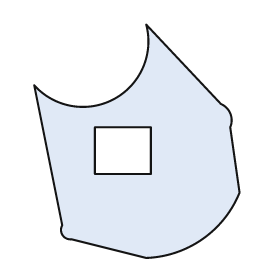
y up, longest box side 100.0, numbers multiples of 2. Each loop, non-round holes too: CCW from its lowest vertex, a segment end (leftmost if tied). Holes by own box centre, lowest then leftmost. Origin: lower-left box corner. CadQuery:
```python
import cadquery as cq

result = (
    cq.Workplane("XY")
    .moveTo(48.0, 0.0)
    .threePointArc((72.0, 8.0), (88.0, 28.0))
    .lineTo(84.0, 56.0)
    .threePointArc((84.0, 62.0), (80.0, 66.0))
    .lineTo(48.0, 100.0)
    .threePointArc((34.0, 68.0), (0.0, 74.0))
    .lineTo(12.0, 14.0)
    .threePointArc((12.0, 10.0), (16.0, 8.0))
    .close()
    .moveTo(26.0, 36.0)
    .lineTo(50.0, 36.0)
    .lineTo(50.0, 56.0)
    .lineTo(26.0, 56.0)
    .close()
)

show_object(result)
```